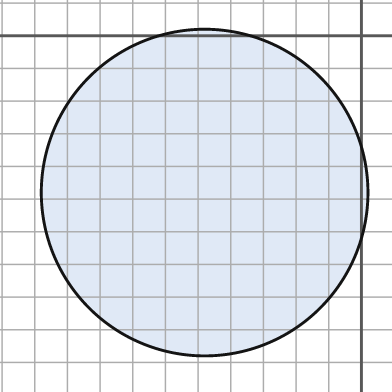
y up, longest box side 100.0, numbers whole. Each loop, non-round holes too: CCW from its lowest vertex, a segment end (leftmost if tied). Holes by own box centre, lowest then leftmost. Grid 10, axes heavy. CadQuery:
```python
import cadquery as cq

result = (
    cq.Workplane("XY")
    .moveTo(-48.0, -48.0)
    .circle(50.0)
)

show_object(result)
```